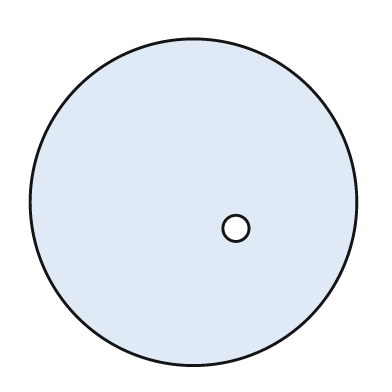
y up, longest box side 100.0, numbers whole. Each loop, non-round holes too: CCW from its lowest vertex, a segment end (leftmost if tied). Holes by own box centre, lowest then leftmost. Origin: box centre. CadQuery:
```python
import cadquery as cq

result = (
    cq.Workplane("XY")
    .moveTo(0.0, 0.0)
    .circle(50.0)
    .moveTo(13.0, -8.0)
    .circle(4.0)
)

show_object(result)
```